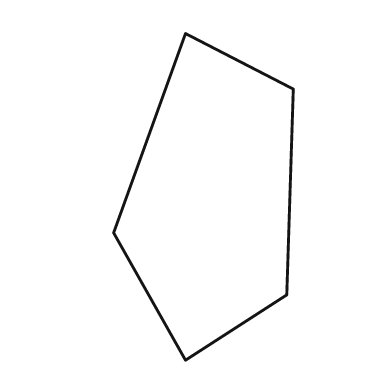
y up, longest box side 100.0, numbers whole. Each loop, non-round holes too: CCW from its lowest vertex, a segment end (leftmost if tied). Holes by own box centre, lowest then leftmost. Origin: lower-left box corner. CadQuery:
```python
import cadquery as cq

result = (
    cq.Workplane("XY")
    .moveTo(22.0, 0.0)
    .lineTo(53.0, 20.0)
    .lineTo(55.0, 83.0)
    .lineTo(22.0, 100.0)
    .lineTo(0.0, 39.0)
    .close()
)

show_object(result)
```